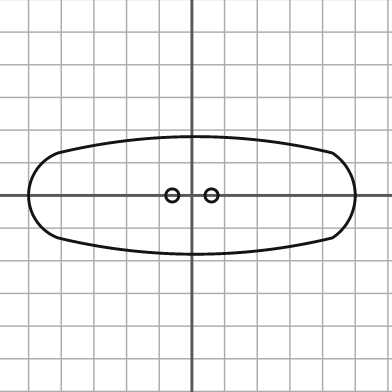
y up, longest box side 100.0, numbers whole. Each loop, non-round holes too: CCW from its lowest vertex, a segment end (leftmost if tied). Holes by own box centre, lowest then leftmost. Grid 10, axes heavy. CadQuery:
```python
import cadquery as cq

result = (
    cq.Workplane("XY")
    .moveTo(-41.0, -13.0)
    .threePointArc((1.0, -18.0), (43.0, -13.0))
    .threePointArc((50.0, 0.0), (43.0, 13.0))
    .threePointArc((1.0, 18.0), (-41.0, 13.0))
    .threePointArc((-50.0, 0.0), (-41.0, -13.0))
    .close()
    .moveTo(-6.0, 0.0)
    .circle(2.0)
    .moveTo(6.0, 0.0)
    .circle(2.0)
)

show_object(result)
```